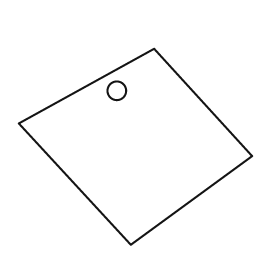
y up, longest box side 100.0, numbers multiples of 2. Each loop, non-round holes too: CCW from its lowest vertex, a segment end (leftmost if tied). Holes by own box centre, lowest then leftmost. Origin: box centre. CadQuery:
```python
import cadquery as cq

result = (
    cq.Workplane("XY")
    .moveTo(-2.0, -42.0)
    .lineTo(50.0, -4.0)
    .lineTo(8.0, 42.0)
    .lineTo(-50.0, 10.0)
    .close()
    .moveTo(-8.0, 24.0)
    .circle(4.0)
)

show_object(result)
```